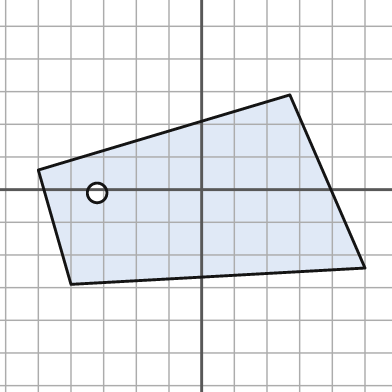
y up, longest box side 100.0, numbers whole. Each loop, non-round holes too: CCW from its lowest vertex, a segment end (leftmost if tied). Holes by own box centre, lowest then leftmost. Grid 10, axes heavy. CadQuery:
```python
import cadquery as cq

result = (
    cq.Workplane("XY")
    .moveTo(-40.0, -29.0)
    .lineTo(50.0, -24.0)
    .lineTo(27.0, 29.0)
    .lineTo(-50.0, 6.0)
    .close()
    .moveTo(-32.0, -1.0)
    .circle(3.0)
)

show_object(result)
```